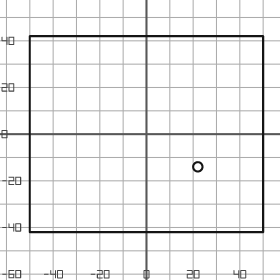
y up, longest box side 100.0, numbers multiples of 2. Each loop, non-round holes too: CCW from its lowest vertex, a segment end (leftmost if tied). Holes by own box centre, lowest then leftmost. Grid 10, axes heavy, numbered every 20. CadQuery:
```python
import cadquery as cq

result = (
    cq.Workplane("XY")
    .moveTo(-50.0, -42.0)
    .lineTo(50.0, -42.0)
    .lineTo(50.0, 42.0)
    .lineTo(-50.0, 42.0)
    .close()
    .moveTo(22.0, -14.0)
    .circle(2.0)
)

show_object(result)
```